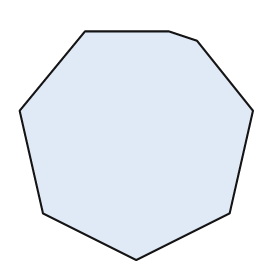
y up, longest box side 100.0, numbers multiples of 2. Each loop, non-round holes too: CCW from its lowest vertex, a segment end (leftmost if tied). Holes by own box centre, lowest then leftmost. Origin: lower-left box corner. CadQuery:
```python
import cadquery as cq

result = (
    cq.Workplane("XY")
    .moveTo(50.0, 0.0)
    .lineTo(90.0, 20.0)
    .lineTo(100.0, 64.0)
    .lineTo(76.0, 94.0)
    .lineTo(64.0, 98.0)
    .lineTo(28.0, 98.0)
    .lineTo(0.0, 64.0)
    .lineTo(10.0, 20.0)
    .close()
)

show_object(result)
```